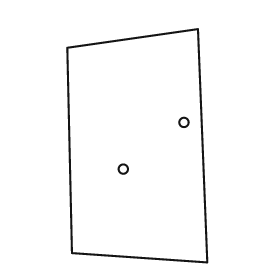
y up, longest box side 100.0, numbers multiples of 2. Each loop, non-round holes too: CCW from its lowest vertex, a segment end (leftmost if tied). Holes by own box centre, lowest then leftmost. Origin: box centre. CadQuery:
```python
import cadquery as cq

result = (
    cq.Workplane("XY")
    .moveTo(30.0, -50.0)
    .lineTo(26.0, 50.0)
    .lineTo(-30.0, 42.0)
    .lineTo(-28.0, -46.0)
    .close()
    .moveTo(-6.0, -10.0)
    .circle(2.0)
    .moveTo(20.0, 10.0)
    .circle(2.0)
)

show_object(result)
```